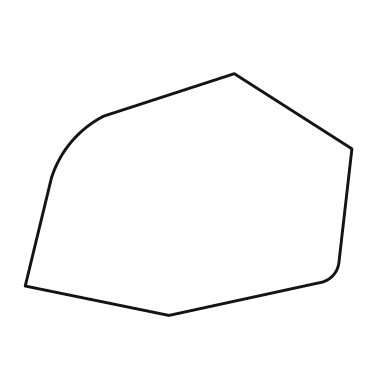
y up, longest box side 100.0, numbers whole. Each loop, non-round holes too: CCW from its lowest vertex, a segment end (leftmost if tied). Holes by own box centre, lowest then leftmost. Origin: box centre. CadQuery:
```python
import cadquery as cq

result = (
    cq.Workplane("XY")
    .moveTo(-6.0, -37.0)
    .lineTo(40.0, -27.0)
    .threePointArc((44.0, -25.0), (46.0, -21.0))
    .lineTo(50.0, 14.0)
    .lineTo(14.0, 37.0)
    .lineTo(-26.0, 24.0)
    .threePointArc((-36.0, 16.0), (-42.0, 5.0))
    .lineTo(-50.0, -28.0)
    .close()
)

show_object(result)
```